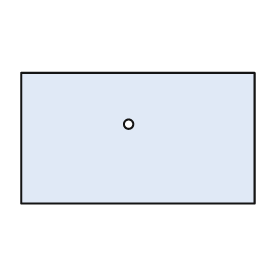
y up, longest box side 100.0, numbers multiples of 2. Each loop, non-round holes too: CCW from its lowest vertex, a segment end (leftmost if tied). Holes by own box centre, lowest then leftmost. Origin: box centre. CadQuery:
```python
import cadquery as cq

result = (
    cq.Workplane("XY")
    .moveTo(-50.0, -28.0)
    .lineTo(50.0, -28.0)
    .lineTo(50.0, 28.0)
    .lineTo(-50.0, 28.0)
    .close()
    .moveTo(-4.0, 6.0)
    .circle(2.0)
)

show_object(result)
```